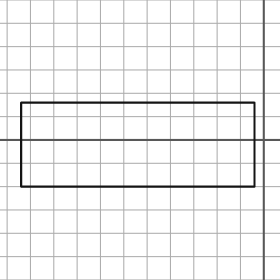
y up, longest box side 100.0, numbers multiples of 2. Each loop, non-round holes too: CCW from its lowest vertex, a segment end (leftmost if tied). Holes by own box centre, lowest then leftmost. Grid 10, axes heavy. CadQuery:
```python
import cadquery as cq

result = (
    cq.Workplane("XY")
    .moveTo(-104.0, -20.0)
    .lineTo(-4.0, -20.0)
    .lineTo(-4.0, 16.0)
    .lineTo(-104.0, 16.0)
    .close()
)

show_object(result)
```